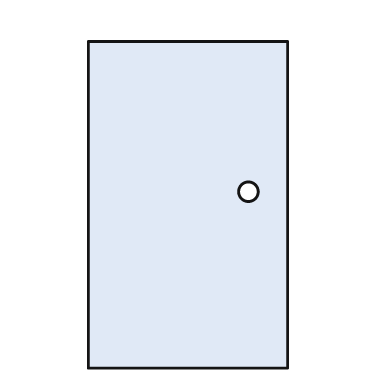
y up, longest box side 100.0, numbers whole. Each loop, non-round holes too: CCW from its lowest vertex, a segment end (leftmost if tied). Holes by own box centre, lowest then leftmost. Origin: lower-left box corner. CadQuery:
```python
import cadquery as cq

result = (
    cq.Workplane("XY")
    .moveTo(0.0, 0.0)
    .lineTo(61.0, 0.0)
    .lineTo(61.0, 100.0)
    .lineTo(0.0, 100.0)
    .close()
    .moveTo(49.0, 54.0)
    .circle(3.0)
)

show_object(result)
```